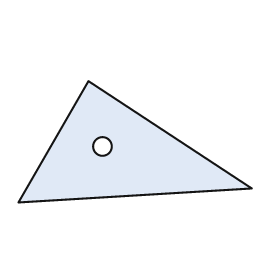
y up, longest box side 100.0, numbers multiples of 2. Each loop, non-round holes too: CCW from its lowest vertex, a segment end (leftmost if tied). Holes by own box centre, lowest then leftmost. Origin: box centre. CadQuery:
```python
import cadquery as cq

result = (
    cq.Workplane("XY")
    .moveTo(-50.0, -26.0)
    .lineTo(50.0, -20.0)
    .lineTo(-20.0, 26.0)
    .close()
    .moveTo(-14.0, -2.0)
    .circle(4.0)
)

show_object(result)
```